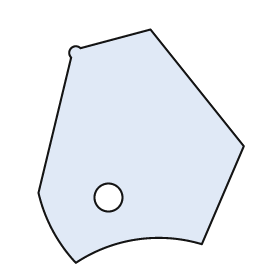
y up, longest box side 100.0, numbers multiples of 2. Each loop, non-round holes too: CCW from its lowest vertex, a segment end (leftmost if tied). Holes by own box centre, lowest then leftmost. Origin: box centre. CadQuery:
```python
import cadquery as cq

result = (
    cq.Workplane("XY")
    .moveTo(-28.0, -50.0)
    .threePointArc((-2.0, -40.0), (26.0, -42.0))
    .lineTo(44.0, 0.0)
    .lineTo(4.0, 50.0)
    .lineTo(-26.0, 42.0)
    .threePointArc((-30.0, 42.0), (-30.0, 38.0))
    .lineTo(-44.0, -20.0)
    .threePointArc((-38.0, -36.0), (-28.0, -50.0))
    .close()
    .moveTo(-14.0, -22.0)
    .circle(6.0)
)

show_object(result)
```